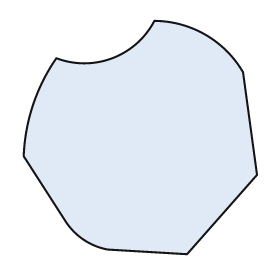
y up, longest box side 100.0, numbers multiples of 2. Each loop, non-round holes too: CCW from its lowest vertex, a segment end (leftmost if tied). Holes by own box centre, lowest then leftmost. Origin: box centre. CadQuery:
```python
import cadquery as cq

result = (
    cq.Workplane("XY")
    .moveTo(20.0, -50.0)
    .lineTo(50.0, -16.0)
    .lineTo(44.0, 28.0)
    .threePointArc((28.0, 44.0), (6.0, 50.0))
    .threePointArc((-12.0, 34.0), (-36.0, 34.0))
    .threePointArc((-46.0, 14.0), (-50.0, -8.0))
    .lineTo(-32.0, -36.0)
    .threePointArc((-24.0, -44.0), (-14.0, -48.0))
    .close()
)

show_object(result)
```